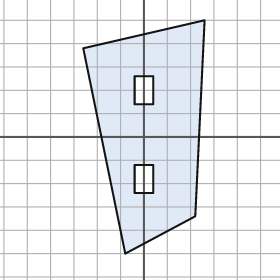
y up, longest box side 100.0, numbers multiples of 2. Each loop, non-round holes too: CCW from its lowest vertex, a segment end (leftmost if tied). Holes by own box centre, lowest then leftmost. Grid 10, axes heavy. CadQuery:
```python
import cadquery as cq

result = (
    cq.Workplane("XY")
    .moveTo(-8.0, -50.0)
    .lineTo(22.0, -34.0)
    .lineTo(26.0, 50.0)
    .lineTo(-26.0, 38.0)
    .close()
    .moveTo(-4.0, -24.0)
    .lineTo(4.0, -24.0)
    .lineTo(4.0, -12.0)
    .lineTo(-4.0, -12.0)
    .close()
    .moveTo(-4.0, 14.0)
    .lineTo(4.0, 14.0)
    .lineTo(4.0, 26.0)
    .lineTo(-4.0, 26.0)
    .close()
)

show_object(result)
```